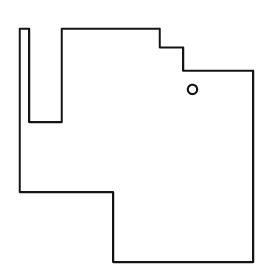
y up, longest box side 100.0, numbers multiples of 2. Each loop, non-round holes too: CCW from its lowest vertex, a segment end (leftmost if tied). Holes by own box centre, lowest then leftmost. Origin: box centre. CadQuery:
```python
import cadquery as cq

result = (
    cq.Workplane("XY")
    .moveTo(-10.0, -50.0)
    .lineTo(50.0, -50.0)
    .lineTo(50.0, 32.0)
    .lineTo(20.0, 32.0)
    .lineTo(20.0, 42.0)
    .lineTo(10.0, 42.0)
    .lineTo(10.0, 50.0)
    .lineTo(-32.0, 50.0)
    .lineTo(-32.0, 10.0)
    .lineTo(-46.0, 10.0)
    .lineTo(-46.0, 50.0)
    .lineTo(-50.0, 50.0)
    .lineTo(-50.0, -20.0)
    .lineTo(-10.0, -20.0)
    .close()
    .moveTo(24.0, 24.0)
    .circle(2.0)
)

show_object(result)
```